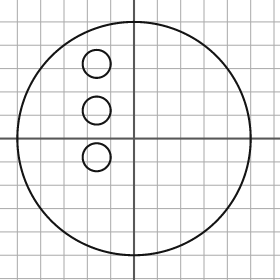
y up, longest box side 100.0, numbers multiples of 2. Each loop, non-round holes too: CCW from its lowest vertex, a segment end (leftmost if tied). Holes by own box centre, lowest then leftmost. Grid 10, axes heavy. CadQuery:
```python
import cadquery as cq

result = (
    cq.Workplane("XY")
    .moveTo(0.0, 0.0)
    .circle(50.0)
    .moveTo(-16.0, -8.0)
    .circle(6.0)
    .moveTo(-16.0, 12.0)
    .circle(6.0)
    .moveTo(-16.0, 32.0)
    .circle(6.0)
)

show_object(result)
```